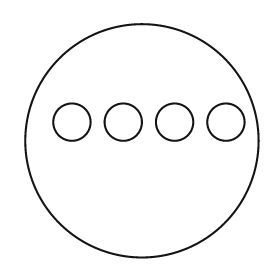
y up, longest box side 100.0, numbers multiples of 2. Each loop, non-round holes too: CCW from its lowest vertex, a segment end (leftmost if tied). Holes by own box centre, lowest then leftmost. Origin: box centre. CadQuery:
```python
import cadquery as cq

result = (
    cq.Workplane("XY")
    .moveTo(0.0, 0.0)
    .circle(50.0)
    .moveTo(-30.0, 8.0)
    .circle(8.0)
    .moveTo(-8.0, 8.0)
    .circle(8.0)
    .moveTo(14.0, 8.0)
    .circle(8.0)
    .moveTo(36.0, 8.0)
    .circle(8.0)
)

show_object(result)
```